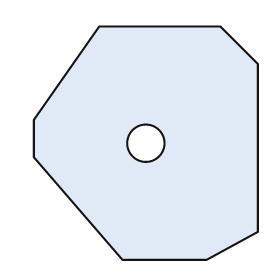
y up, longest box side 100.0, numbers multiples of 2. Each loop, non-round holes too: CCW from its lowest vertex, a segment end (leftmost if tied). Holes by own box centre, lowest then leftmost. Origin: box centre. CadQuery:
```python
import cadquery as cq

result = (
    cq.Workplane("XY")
    .moveTo(-10.0, -50.0)
    .lineTo(26.0, -50.0)
    .lineTo(48.0, -38.0)
    .lineTo(48.0, 34.0)
    .lineTo(32.0, 50.0)
    .lineTo(-20.0, 50.0)
    .lineTo(-48.0, 10.0)
    .lineTo(-48.0, -6.0)
    .close()
    .moveTo(0.0, 0.0)
    .circle(8.0)
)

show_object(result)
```